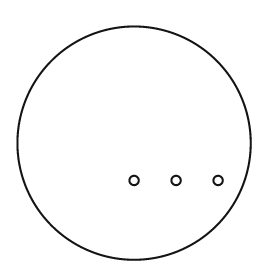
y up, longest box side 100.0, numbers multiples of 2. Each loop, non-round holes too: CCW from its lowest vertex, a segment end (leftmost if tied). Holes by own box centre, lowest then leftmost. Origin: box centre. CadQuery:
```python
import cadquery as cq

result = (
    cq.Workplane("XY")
    .moveTo(0.0, 0.0)
    .circle(50.0)
    .moveTo(0.0, -16.0)
    .circle(2.0)
    .moveTo(18.0, -16.0)
    .circle(2.0)
    .moveTo(36.0, -16.0)
    .circle(2.0)
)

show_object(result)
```